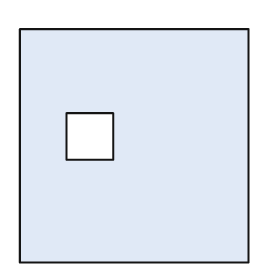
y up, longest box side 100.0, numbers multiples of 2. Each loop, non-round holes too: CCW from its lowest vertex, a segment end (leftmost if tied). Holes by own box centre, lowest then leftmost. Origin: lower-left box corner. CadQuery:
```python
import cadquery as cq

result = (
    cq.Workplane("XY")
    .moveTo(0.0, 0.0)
    .lineTo(98.0, 0.0)
    .lineTo(98.0, 100.0)
    .lineTo(0.0, 100.0)
    .close()
    .moveTo(20.0, 44.0)
    .lineTo(40.0, 44.0)
    .lineTo(40.0, 64.0)
    .lineTo(20.0, 64.0)
    .close()
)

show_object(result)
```